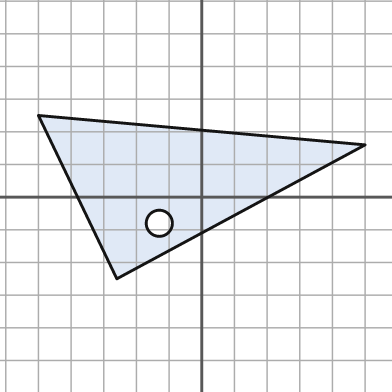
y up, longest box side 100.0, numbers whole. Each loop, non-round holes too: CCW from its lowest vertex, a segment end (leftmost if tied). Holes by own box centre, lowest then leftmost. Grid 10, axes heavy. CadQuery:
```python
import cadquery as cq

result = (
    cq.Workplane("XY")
    .moveTo(-26.0, -25.0)
    .lineTo(50.0, 16.0)
    .lineTo(-50.0, 25.0)
    .close()
    .moveTo(-13.0, -8.0)
    .circle(4.0)
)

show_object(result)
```